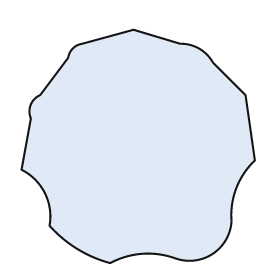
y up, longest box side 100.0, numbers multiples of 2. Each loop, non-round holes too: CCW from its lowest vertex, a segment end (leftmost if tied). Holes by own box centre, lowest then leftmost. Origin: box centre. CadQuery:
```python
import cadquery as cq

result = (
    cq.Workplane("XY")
    .moveTo(-12.0, -50.0)
    .threePointArc((2.0, -46.0), (16.0, -48.0))
    .threePointArc((32.0, -46.0), (40.0, -32.0))
    .threePointArc((42.0, -18.0), (50.0, -6.0))
    .lineTo(46.0, 22.0)
    .lineTo(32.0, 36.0)
    .threePointArc((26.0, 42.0), (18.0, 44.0))
    .lineTo(-2.0, 50.0)
    .lineTo(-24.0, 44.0)
    .threePointArc((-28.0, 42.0), (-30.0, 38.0))
    .lineTo(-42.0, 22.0)
    .threePointArc((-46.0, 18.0), (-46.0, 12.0))
    .lineTo(-50.0, -10.0)
    .threePointArc((-40.0, -20.0), (-38.0, -34.0))
    .threePointArc((-26.0, -44.0), (-12.0, -50.0))
    .close()
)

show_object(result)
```